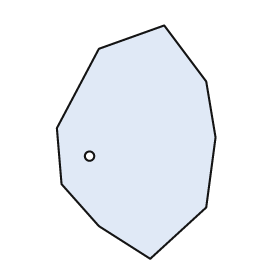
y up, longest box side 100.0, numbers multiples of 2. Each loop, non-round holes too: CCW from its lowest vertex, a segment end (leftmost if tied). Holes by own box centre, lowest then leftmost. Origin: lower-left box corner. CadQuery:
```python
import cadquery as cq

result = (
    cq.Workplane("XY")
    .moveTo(40.0, 0.0)
    .lineTo(64.0, 22.0)
    .lineTo(68.0, 52.0)
    .lineTo(64.0, 76.0)
    .lineTo(46.0, 100.0)
    .lineTo(18.0, 90.0)
    .lineTo(0.0, 56.0)
    .lineTo(2.0, 32.0)
    .lineTo(18.0, 14.0)
    .close()
    .moveTo(14.0, 44.0)
    .circle(2.0)
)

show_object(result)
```